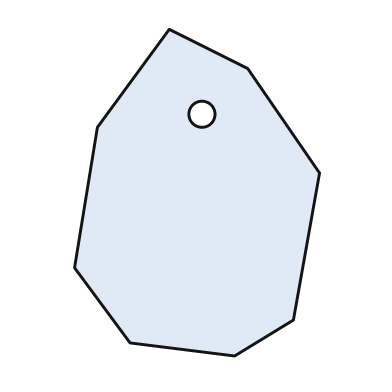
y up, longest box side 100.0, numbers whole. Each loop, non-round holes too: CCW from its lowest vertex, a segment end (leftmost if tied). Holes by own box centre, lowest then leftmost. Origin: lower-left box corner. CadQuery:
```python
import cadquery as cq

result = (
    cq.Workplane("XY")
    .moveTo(49.0, 0.0)
    .lineTo(67.0, 11.0)
    .lineTo(75.0, 56.0)
    .lineTo(53.0, 88.0)
    .lineTo(29.0, 100.0)
    .lineTo(7.0, 70.0)
    .lineTo(0.0, 27.0)
    .lineTo(17.0, 4.0)
    .close()
    .moveTo(39.0, 74.0)
    .circle(4.0)
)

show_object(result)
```